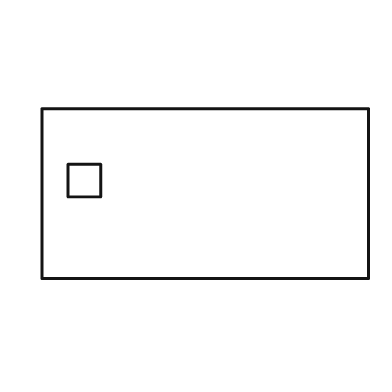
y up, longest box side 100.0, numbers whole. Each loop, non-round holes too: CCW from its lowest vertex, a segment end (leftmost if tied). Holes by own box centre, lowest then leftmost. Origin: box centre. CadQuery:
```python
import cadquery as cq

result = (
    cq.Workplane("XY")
    .moveTo(-50.0, -26.0)
    .lineTo(50.0, -26.0)
    .lineTo(50.0, 26.0)
    .lineTo(-50.0, 26.0)
    .close()
    .moveTo(-42.0, -1.0)
    .lineTo(-32.0, -1.0)
    .lineTo(-32.0, 9.0)
    .lineTo(-42.0, 9.0)
    .close()
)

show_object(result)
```